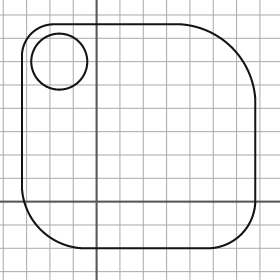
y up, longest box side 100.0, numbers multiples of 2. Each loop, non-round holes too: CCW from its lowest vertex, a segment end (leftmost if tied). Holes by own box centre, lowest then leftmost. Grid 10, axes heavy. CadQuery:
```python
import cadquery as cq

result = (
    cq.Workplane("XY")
    .moveTo(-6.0, -20.0)
    .lineTo(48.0, -20.0)
    .threePointArc((62.0, -14.0), (68.0, 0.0))
    .lineTo(68.0, 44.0)
    .threePointArc((58.0, 66.0), (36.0, 76.0))
    .lineTo(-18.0, 76.0)
    .threePointArc((-28.0, 72.0), (-32.0, 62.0))
    .lineTo(-32.0, 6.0)
    .threePointArc((-24.0, -12.0), (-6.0, -20.0))
    .close()
    .moveTo(-16.0, 60.0)
    .circle(12.0)
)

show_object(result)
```